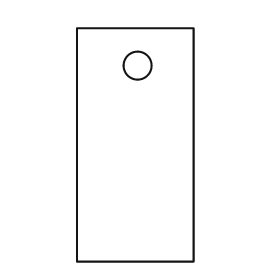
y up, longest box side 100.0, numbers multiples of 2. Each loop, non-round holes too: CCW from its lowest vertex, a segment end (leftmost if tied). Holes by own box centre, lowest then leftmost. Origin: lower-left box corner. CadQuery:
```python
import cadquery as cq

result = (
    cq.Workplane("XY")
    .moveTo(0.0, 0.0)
    .lineTo(50.0, 0.0)
    .lineTo(50.0, 100.0)
    .lineTo(0.0, 100.0)
    .close()
    .moveTo(26.0, 84.0)
    .circle(6.0)
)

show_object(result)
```